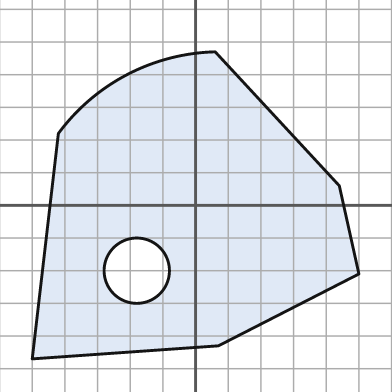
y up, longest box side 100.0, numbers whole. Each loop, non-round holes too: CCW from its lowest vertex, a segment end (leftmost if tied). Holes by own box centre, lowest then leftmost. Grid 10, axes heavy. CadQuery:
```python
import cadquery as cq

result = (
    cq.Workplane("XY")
    .moveTo(-50.0, -47.0)
    .lineTo(7.0, -43.0)
    .lineTo(50.0, -21.0)
    .lineTo(44.0, 6.0)
    .lineTo(6.0, 47.0)
    .threePointArc((-21.0, 40.0), (-42.0, 22.0))
    .close()
    .moveTo(-18.0, -20.0)
    .circle(10.0)
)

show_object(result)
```